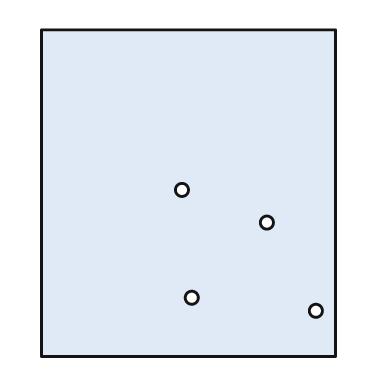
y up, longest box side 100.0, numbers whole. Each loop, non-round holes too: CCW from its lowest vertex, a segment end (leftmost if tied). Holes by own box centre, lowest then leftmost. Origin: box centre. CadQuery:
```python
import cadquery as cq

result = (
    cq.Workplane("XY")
    .moveTo(-45.0, -50.0)
    .lineTo(45.0, -50.0)
    .lineTo(45.0, 50.0)
    .lineTo(-45.0, 50.0)
    .close()
    .moveTo(39.0, -36.0)
    .circle(2.0)
    .moveTo(1.0, -32.0)
    .circle(2.0)
    .moveTo(24.0, -9.0)
    .circle(2.0)
    .moveTo(-2.0, 1.0)
    .circle(2.0)
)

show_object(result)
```